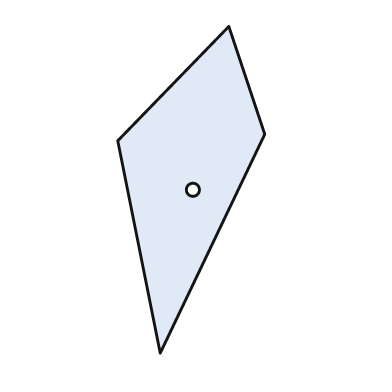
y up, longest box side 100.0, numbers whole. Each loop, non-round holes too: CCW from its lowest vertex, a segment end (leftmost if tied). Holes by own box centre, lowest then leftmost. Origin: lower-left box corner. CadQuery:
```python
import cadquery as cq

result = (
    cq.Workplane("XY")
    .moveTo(13.0, 0.0)
    .lineTo(45.0, 67.0)
    .lineTo(34.0, 100.0)
    .lineTo(0.0, 65.0)
    .close()
    .moveTo(23.0, 50.0)
    .circle(2.0)
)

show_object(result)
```